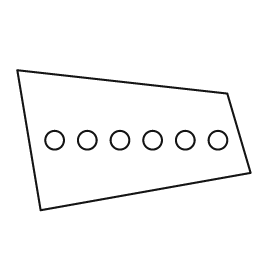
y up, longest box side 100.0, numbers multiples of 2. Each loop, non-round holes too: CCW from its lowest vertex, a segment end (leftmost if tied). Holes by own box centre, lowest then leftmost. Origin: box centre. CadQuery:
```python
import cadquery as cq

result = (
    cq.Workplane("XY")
    .moveTo(-40.0, -30.0)
    .lineTo(50.0, -14.0)
    .lineTo(40.0, 20.0)
    .lineTo(-50.0, 30.0)
    .close()
    .moveTo(-34.0, 0.0)
    .circle(4.0)
    .moveTo(-20.0, 0.0)
    .circle(4.0)
    .moveTo(-6.0, 0.0)
    .circle(4.0)
    .moveTo(8.0, 0.0)
    .circle(4.0)
    .moveTo(22.0, 0.0)
    .circle(4.0)
    .moveTo(36.0, 0.0)
    .circle(4.0)
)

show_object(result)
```